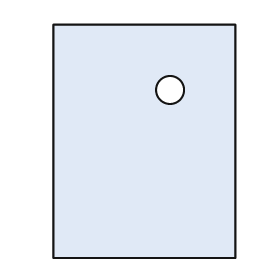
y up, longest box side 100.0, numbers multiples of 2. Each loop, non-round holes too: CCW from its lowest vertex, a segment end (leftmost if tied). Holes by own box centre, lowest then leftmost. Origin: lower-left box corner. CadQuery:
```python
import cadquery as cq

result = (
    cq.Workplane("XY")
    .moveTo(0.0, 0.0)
    .lineTo(78.0, 0.0)
    .lineTo(78.0, 100.0)
    .lineTo(0.0, 100.0)
    .close()
    .moveTo(50.0, 72.0)
    .circle(6.0)
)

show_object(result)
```